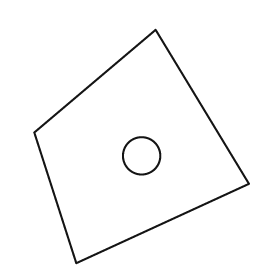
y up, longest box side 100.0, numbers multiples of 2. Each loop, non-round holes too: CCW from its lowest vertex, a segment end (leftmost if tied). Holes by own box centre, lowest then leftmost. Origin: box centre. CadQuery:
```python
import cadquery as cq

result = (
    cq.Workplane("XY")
    .moveTo(-28.0, -50.0)
    .lineTo(46.0, -16.0)
    .lineTo(6.0, 50.0)
    .lineTo(-46.0, 6.0)
    .close()
    .moveTo(0.0, -4.0)
    .circle(8.0)
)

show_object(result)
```